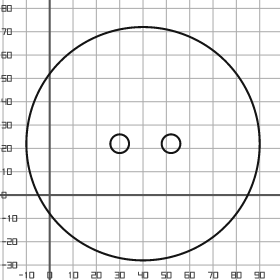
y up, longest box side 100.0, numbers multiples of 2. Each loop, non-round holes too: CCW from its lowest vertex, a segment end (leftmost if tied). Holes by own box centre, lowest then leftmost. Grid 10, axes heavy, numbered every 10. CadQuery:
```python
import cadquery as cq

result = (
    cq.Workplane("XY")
    .moveTo(40.0, 22.0)
    .circle(50.0)
    .moveTo(30.0, 22.0)
    .circle(4.0)
    .moveTo(52.0, 22.0)
    .circle(4.0)
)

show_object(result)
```